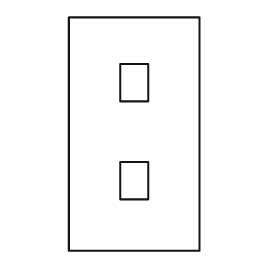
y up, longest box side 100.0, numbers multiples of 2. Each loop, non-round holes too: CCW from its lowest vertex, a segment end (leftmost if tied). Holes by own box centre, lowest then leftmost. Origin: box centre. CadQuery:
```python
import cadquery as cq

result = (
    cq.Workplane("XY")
    .moveTo(-28.0, -50.0)
    .lineTo(28.0, -50.0)
    .lineTo(28.0, 50.0)
    .lineTo(-28.0, 50.0)
    .close()
    .moveTo(-6.0, -28.0)
    .lineTo(6.0, -28.0)
    .lineTo(6.0, -12.0)
    .lineTo(-6.0, -12.0)
    .close()
    .moveTo(-6.0, 14.0)
    .lineTo(6.0, 14.0)
    .lineTo(6.0, 30.0)
    .lineTo(-6.0, 30.0)
    .close()
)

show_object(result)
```